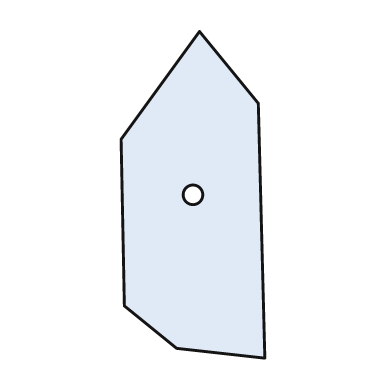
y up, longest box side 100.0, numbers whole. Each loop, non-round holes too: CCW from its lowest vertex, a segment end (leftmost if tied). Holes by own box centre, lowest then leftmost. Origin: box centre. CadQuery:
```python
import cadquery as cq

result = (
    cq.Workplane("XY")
    .moveTo(22.0, -50.0)
    .lineTo(20.0, 28.0)
    .lineTo(2.0, 50.0)
    .lineTo(-22.0, 17.0)
    .lineTo(-21.0, -34.0)
    .lineTo(-5.0, -47.0)
    .close()
    .moveTo(0.0, 0.0)
    .circle(3.0)
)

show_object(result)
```